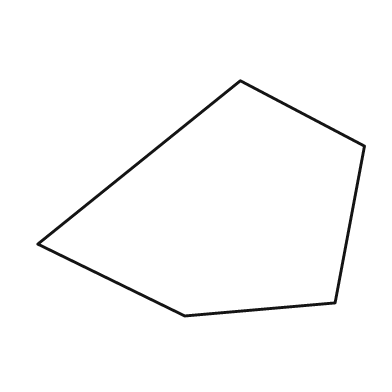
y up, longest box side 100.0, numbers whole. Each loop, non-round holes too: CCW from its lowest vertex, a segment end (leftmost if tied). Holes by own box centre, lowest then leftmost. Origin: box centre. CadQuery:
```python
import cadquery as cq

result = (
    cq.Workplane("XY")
    .moveTo(-5.0, -36.0)
    .lineTo(41.0, -32.0)
    .lineTo(50.0, 16.0)
    .lineTo(12.0, 36.0)
    .lineTo(-50.0, -14.0)
    .close()
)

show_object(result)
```